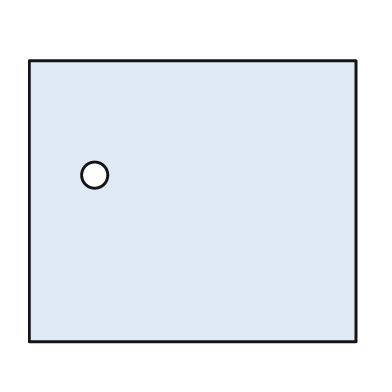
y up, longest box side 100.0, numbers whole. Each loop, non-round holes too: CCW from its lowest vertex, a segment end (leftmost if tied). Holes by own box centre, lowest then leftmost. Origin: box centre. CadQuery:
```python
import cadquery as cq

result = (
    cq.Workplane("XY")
    .moveTo(-50.0, -43.0)
    .lineTo(50.0, -43.0)
    .lineTo(50.0, 43.0)
    .lineTo(-50.0, 43.0)
    .close()
    .moveTo(-30.0, 8.0)
    .circle(4.0)
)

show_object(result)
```